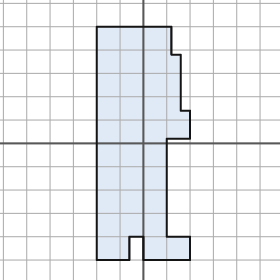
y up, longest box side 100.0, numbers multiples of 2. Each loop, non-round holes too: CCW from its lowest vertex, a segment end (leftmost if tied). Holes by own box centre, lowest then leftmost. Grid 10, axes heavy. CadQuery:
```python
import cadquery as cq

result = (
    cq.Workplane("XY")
    .moveTo(-20.0, -50.0)
    .lineTo(-6.0, -50.0)
    .lineTo(-6.0, -40.0)
    .lineTo(0.0, -40.0)
    .lineTo(0.0, -50.0)
    .lineTo(20.0, -50.0)
    .lineTo(20.0, -40.0)
    .lineTo(10.0, -40.0)
    .lineTo(10.0, 2.0)
    .lineTo(20.0, 2.0)
    .lineTo(20.0, 14.0)
    .lineTo(16.0, 14.0)
    .lineTo(16.0, 38.0)
    .lineTo(12.0, 38.0)
    .lineTo(12.0, 50.0)
    .lineTo(-20.0, 50.0)
    .close()
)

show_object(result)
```